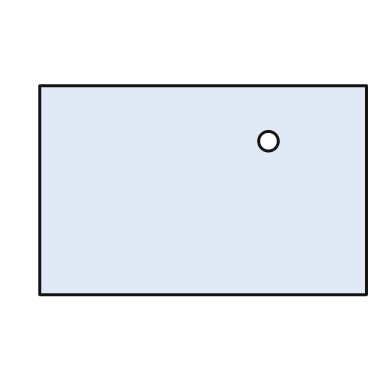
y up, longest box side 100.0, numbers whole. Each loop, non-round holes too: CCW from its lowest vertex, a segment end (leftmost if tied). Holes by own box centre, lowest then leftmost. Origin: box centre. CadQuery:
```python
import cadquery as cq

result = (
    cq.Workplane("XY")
    .moveTo(-50.0, -32.0)
    .lineTo(50.0, -32.0)
    .lineTo(50.0, 32.0)
    .lineTo(-50.0, 32.0)
    .close()
    .moveTo(20.0, 15.0)
    .circle(3.0)
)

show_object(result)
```